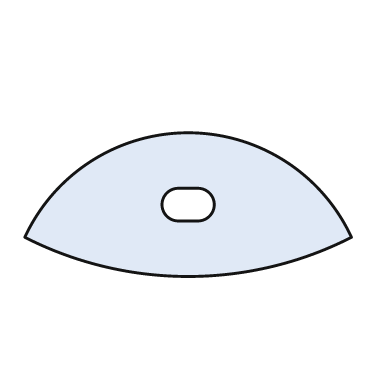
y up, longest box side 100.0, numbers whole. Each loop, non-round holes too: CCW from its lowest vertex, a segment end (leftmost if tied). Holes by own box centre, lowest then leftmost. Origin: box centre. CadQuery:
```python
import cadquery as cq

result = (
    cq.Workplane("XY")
    .moveTo(-50.0, -10.0)
    .threePointArc((0.0, -22.0), (50.0, -10.0))
    .threePointArc((0.0, 22.0), (-50.0, -10.0))
    .close()
    .moveTo(-3.0, -5.0)
    .lineTo(3.0, -5.0)
    .threePointArc((8.0, 0.0), (3.0, 5.0))
    .lineTo(-3.0, 5.0)
    .threePointArc((-8.0, 0.0), (-3.0, -5.0))
    .close()
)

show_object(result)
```